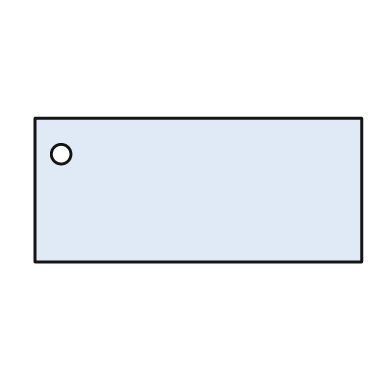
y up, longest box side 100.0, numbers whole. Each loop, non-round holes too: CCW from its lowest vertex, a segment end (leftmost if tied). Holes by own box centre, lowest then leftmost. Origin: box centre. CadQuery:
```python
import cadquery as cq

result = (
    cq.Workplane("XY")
    .moveTo(-50.0, -22.0)
    .lineTo(50.0, -22.0)
    .lineTo(50.0, 22.0)
    .lineTo(-50.0, 22.0)
    .close()
    .moveTo(-42.0, 11.0)
    .circle(3.0)
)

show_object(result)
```